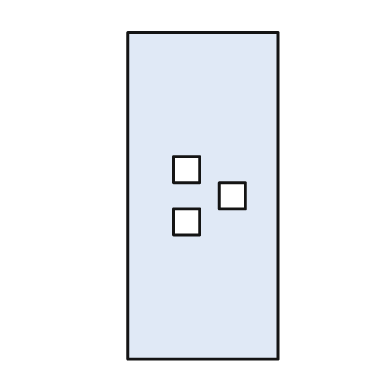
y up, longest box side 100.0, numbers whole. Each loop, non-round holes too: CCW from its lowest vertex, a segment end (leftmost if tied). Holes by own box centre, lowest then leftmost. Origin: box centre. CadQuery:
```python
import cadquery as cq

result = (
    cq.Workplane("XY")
    .moveTo(-23.0, -50.0)
    .lineTo(23.0, -50.0)
    .lineTo(23.0, 50.0)
    .lineTo(-23.0, 50.0)
    .close()
    .moveTo(-9.0, -12.0)
    .lineTo(-1.0, -12.0)
    .lineTo(-1.0, -4.0)
    .lineTo(-9.0, -4.0)
    .close()
    .moveTo(5.0, -4.0)
    .lineTo(13.0, -4.0)
    .lineTo(13.0, 4.0)
    .lineTo(5.0, 4.0)
    .close()
    .moveTo(-9.0, 4.0)
    .lineTo(-1.0, 4.0)
    .lineTo(-1.0, 12.0)
    .lineTo(-9.0, 12.0)
    .close()
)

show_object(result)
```